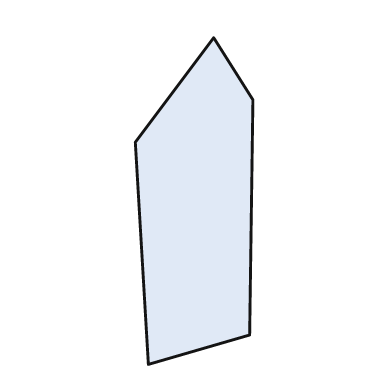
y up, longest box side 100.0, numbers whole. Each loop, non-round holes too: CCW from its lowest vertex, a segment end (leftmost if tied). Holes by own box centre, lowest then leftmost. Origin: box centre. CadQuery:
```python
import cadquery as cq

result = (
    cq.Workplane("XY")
    .moveTo(-14.0, -50.0)
    .lineTo(17.0, -41.0)
    .lineTo(18.0, 31.0)
    .lineTo(6.0, 50.0)
    .lineTo(-18.0, 18.0)
    .close()
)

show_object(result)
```